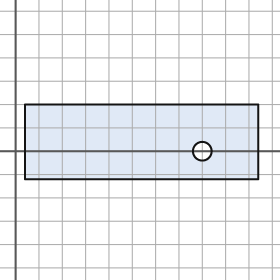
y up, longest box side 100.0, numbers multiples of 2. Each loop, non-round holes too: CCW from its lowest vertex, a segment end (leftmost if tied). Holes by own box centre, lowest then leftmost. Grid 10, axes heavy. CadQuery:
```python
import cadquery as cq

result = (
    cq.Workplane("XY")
    .moveTo(4.0, -12.0)
    .lineTo(104.0, -12.0)
    .lineTo(104.0, 20.0)
    .lineTo(4.0, 20.0)
    .close()
    .moveTo(80.0, 0.0)
    .circle(4.0)
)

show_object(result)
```